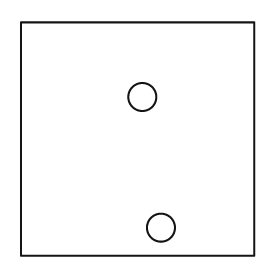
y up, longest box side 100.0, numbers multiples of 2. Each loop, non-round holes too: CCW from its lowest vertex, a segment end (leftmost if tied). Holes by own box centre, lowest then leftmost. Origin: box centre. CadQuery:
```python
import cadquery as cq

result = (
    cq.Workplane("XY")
    .moveTo(-50.0, -50.0)
    .lineTo(50.0, -50.0)
    .lineTo(50.0, 50.0)
    .lineTo(-50.0, 50.0)
    .close()
    .moveTo(10.0, -38.0)
    .circle(6.0)
    .moveTo(2.0, 18.0)
    .circle(6.0)
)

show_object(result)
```